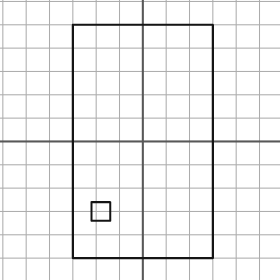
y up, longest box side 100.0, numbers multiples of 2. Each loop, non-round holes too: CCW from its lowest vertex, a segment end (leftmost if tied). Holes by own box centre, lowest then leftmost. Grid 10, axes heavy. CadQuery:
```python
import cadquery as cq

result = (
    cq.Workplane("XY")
    .moveTo(-30.0, -50.0)
    .lineTo(30.0, -50.0)
    .lineTo(30.0, 50.0)
    .lineTo(-30.0, 50.0)
    .close()
    .moveTo(-22.0, -34.0)
    .lineTo(-14.0, -34.0)
    .lineTo(-14.0, -26.0)
    .lineTo(-22.0, -26.0)
    .close()
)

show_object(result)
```